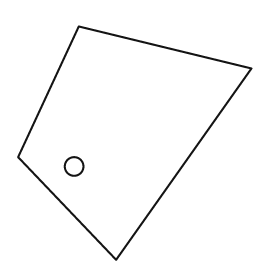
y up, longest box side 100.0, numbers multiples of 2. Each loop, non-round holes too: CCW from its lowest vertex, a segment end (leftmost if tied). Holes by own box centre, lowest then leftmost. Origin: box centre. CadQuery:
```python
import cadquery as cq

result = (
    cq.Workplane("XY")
    .moveTo(-8.0, -50.0)
    .lineTo(50.0, 32.0)
    .lineTo(-24.0, 50.0)
    .lineTo(-50.0, -6.0)
    .close()
    .moveTo(-26.0, -10.0)
    .circle(4.0)
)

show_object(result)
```